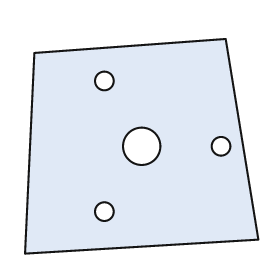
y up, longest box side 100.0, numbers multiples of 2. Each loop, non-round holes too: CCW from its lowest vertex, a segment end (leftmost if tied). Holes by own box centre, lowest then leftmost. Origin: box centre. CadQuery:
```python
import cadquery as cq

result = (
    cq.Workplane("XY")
    .moveTo(-50.0, -46.0)
    .lineTo(50.0, -40.0)
    .lineTo(36.0, 46.0)
    .lineTo(-46.0, 40.0)
    .close()
    .moveTo(-16.0, -28.0)
    .circle(4.0)
    .moveTo(0.0, 0.0)
    .circle(8.0)
    .moveTo(34.0, 0.0)
    .circle(4.0)
    .moveTo(-16.0, 28.0)
    .circle(4.0)
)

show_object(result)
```